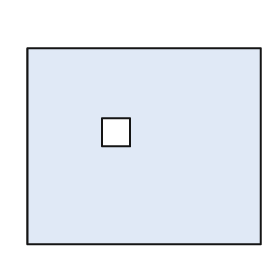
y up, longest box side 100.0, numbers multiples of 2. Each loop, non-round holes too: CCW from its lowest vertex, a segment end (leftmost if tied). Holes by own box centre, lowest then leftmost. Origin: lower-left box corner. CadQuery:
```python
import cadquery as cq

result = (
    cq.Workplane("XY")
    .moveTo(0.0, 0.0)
    .lineTo(100.0, 0.0)
    .lineTo(100.0, 84.0)
    .lineTo(0.0, 84.0)
    .close()
    .moveTo(32.0, 42.0)
    .lineTo(44.0, 42.0)
    .lineTo(44.0, 54.0)
    .lineTo(32.0, 54.0)
    .close()
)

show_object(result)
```